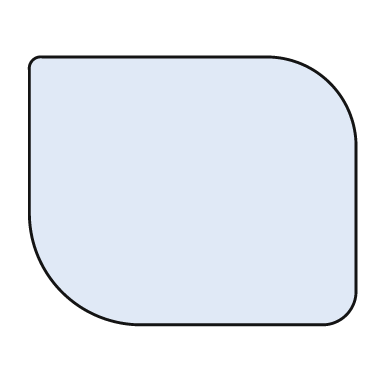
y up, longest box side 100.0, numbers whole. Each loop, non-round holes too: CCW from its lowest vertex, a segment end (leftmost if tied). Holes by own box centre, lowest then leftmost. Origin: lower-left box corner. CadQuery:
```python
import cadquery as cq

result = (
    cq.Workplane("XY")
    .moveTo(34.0, 0.0)
    .lineTo(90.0, 0.0)
    .threePointArc((97.0, 3.0), (100.0, 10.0))
    .lineTo(100.0, 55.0)
    .threePointArc((92.0, 74.0), (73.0, 82.0))
    .lineTo(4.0, 82.0)
    .threePointArc((1.0, 81.0), (0.0, 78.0))
    .lineTo(0.0, 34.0)
    .threePointArc((10.0, 10.0), (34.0, 0.0))
    .close()
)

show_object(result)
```